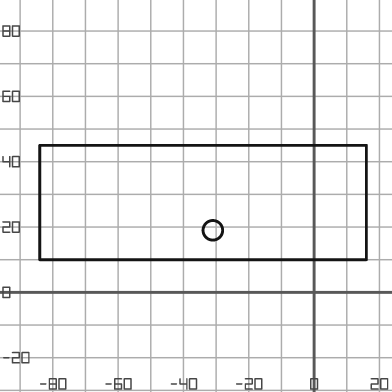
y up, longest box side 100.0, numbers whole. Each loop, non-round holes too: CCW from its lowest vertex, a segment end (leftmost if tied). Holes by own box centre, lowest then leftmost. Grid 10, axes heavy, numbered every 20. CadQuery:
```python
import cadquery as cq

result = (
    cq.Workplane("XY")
    .moveTo(-84.0, 10.0)
    .lineTo(16.0, 10.0)
    .lineTo(16.0, 45.0)
    .lineTo(-84.0, 45.0)
    .close()
    .moveTo(-31.0, 19.0)
    .circle(3.0)
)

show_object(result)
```